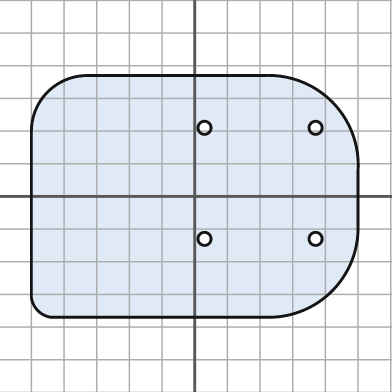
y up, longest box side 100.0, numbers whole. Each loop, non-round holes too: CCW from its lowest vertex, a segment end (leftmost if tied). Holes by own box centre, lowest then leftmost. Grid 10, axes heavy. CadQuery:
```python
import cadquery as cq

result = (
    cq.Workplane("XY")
    .moveTo(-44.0, -37.0)
    .lineTo(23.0, -37.0)
    .threePointArc((42.0, -29.0), (50.0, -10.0))
    .lineTo(50.0, 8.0)
    .threePointArc((42.0, 29.0), (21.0, 37.0))
    .lineTo(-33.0, 37.0)
    .threePointArc((-45.0, 32.0), (-50.0, 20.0))
    .lineTo(-50.0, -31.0)
    .threePointArc((-48.0, -35.0), (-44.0, -37.0))
    .close()
    .moveTo(3.0, -13.0)
    .circle(2.0)
    .moveTo(37.0, -13.0)
    .circle(2.0)
    .moveTo(3.0, 21.0)
    .circle(2.0)
    .moveTo(37.0, 21.0)
    .circle(2.0)
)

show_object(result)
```